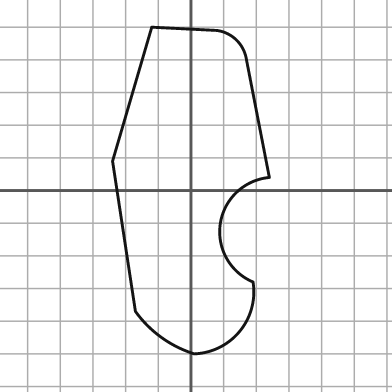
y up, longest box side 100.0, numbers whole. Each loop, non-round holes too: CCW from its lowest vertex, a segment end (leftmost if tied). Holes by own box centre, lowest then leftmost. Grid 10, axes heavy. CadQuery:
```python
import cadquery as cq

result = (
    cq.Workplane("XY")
    .moveTo(1.0, -50.0)
    .threePointArc((15.0, -43.0), (19.0, -28.0))
    .threePointArc((9.0, -10.0), (24.0, 4.0))
    .lineTo(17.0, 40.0)
    .threePointArc((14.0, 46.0), (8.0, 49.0))
    .lineTo(-12.0, 50.0)
    .lineTo(-24.0, 9.0)
    .lineTo(-17.0, -37.0)
    .threePointArc((-9.0, -45.0), (1.0, -50.0))
    .close()
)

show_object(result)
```